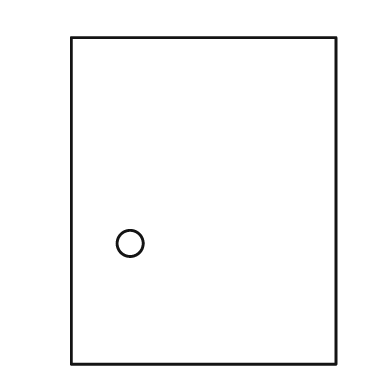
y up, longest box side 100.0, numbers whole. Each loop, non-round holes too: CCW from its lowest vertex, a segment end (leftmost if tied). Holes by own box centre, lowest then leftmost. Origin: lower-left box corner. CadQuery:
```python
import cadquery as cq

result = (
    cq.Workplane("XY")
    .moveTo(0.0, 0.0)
    .lineTo(81.0, 0.0)
    .lineTo(81.0, 100.0)
    .lineTo(0.0, 100.0)
    .close()
    .moveTo(18.0, 37.0)
    .circle(4.0)
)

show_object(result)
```